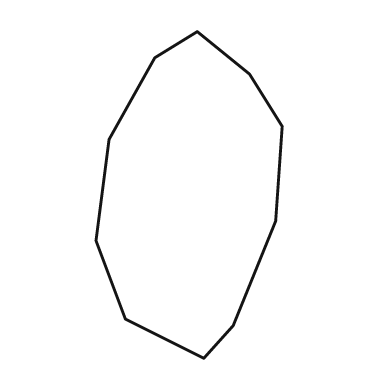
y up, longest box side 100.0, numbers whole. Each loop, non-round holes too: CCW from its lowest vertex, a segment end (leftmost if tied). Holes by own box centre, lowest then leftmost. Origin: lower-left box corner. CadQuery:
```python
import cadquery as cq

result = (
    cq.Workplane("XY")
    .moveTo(33.0, 0.0)
    .lineTo(42.0, 10.0)
    .lineTo(55.0, 42.0)
    .lineTo(57.0, 71.0)
    .lineTo(47.0, 87.0)
    .lineTo(31.0, 100.0)
    .lineTo(18.0, 92.0)
    .lineTo(4.0, 67.0)
    .lineTo(0.0, 36.0)
    .lineTo(9.0, 12.0)
    .close()
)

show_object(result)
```